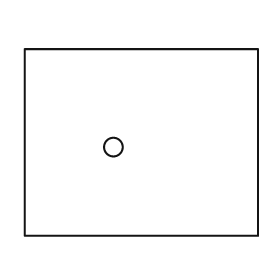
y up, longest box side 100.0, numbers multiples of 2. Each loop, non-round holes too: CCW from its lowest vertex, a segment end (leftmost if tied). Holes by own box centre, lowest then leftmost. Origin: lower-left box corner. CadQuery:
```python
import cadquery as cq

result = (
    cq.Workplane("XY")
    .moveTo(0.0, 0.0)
    .lineTo(100.0, 0.0)
    .lineTo(100.0, 80.0)
    .lineTo(0.0, 80.0)
    .close()
    .moveTo(38.0, 38.0)
    .circle(4.0)
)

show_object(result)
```